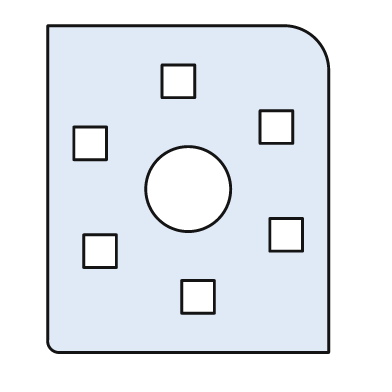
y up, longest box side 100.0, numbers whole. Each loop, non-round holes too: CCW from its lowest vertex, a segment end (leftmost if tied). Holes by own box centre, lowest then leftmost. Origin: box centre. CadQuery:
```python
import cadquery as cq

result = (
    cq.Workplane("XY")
    .moveTo(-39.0, -50.0)
    .lineTo(43.0, -50.0)
    .lineTo(43.0, 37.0)
    .threePointArc((39.0, 46.0), (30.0, 50.0))
    .lineTo(-43.0, 50.0)
    .lineTo(-43.0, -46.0)
    .threePointArc((-42.0, -49.0), (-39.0, -50.0))
    .close()
    .moveTo(-2.0, -38.0)
    .lineTo(8.0, -38.0)
    .lineTo(8.0, -28.0)
    .lineTo(-2.0, -28.0)
    .close()
    .moveTo(-32.0, -24.0)
    .lineTo(-22.0, -24.0)
    .lineTo(-22.0, -14.0)
    .lineTo(-32.0, -14.0)
    .close()
    .moveTo(25.0, -19.0)
    .lineTo(35.0, -19.0)
    .lineTo(35.0, -9.0)
    .lineTo(25.0, -9.0)
    .close()
    .moveTo(0.0, 0.0)
    .circle(13.0)
    .moveTo(-35.0, 9.0)
    .lineTo(-25.0, 9.0)
    .lineTo(-25.0, 19.0)
    .lineTo(-35.0, 19.0)
    .close()
    .moveTo(22.0, 14.0)
    .lineTo(32.0, 14.0)
    .lineTo(32.0, 24.0)
    .lineTo(22.0, 24.0)
    .close()
    .moveTo(-8.0, 28.0)
    .lineTo(2.0, 28.0)
    .lineTo(2.0, 38.0)
    .lineTo(-8.0, 38.0)
    .close()
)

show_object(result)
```